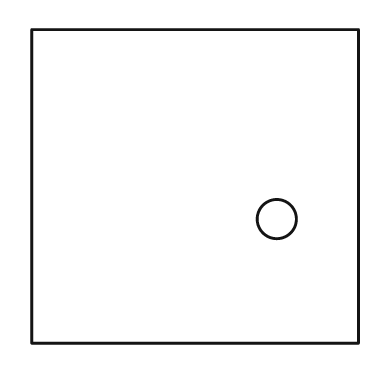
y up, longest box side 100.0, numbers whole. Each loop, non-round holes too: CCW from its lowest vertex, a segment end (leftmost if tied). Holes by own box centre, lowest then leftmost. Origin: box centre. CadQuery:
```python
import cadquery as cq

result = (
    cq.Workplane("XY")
    .moveTo(-50.0, -48.0)
    .lineTo(50.0, -48.0)
    .lineTo(50.0, 48.0)
    .lineTo(-50.0, 48.0)
    .close()
    .moveTo(25.0, -10.0)
    .circle(6.0)
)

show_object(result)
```